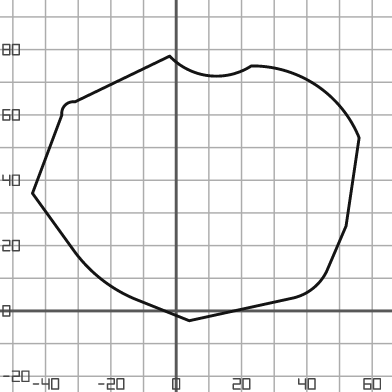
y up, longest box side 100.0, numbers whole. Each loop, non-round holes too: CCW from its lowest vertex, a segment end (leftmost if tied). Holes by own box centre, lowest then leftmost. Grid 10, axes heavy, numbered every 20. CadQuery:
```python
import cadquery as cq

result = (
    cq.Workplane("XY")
    .moveTo(4.0, -3.0)
    .lineTo(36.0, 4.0)
    .threePointArc((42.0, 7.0), (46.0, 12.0))
    .lineTo(52.0, 26.0)
    .lineTo(56.0, 53.0)
    .threePointArc((43.0, 69.0), (23.0, 75.0))
    .threePointArc((10.0, 72.0), (-2.0, 78.0))
    .lineTo(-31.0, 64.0)
    .threePointArc((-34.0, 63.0), (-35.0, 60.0))
    .lineTo(-44.0, 36.0)
    .lineTo(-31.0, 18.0)
    .threePointArc((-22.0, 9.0), (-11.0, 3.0))
    .close()
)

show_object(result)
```